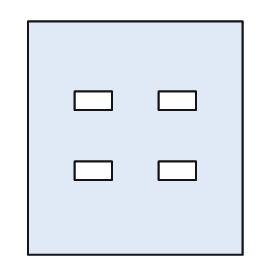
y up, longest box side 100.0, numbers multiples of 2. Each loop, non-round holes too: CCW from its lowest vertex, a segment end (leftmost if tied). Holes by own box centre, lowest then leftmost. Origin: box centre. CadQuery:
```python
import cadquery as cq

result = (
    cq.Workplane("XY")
    .moveTo(-46.0, -50.0)
    .lineTo(46.0, -50.0)
    .lineTo(46.0, 50.0)
    .lineTo(-46.0, 50.0)
    .close()
    .moveTo(-26.0, -18.0)
    .lineTo(-10.0, -18.0)
    .lineTo(-10.0, -10.0)
    .lineTo(-26.0, -10.0)
    .close()
    .moveTo(10.0, -18.0)
    .lineTo(26.0, -18.0)
    .lineTo(26.0, -10.0)
    .lineTo(10.0, -10.0)
    .close()
    .moveTo(-26.0, 12.0)
    .lineTo(-10.0, 12.0)
    .lineTo(-10.0, 20.0)
    .lineTo(-26.0, 20.0)
    .close()
    .moveTo(10.0, 12.0)
    .lineTo(26.0, 12.0)
    .lineTo(26.0, 20.0)
    .lineTo(10.0, 20.0)
    .close()
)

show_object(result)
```